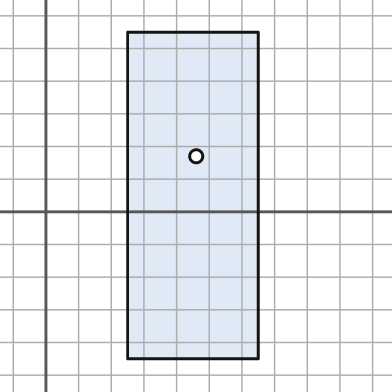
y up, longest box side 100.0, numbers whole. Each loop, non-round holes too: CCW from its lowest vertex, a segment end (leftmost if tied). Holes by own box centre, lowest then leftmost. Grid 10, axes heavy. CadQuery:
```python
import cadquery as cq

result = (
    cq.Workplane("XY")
    .moveTo(25.0, -45.0)
    .lineTo(65.0, -45.0)
    .lineTo(65.0, 55.0)
    .lineTo(25.0, 55.0)
    .close()
    .moveTo(46.0, 17.0)
    .circle(2.0)
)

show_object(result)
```